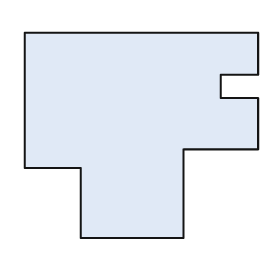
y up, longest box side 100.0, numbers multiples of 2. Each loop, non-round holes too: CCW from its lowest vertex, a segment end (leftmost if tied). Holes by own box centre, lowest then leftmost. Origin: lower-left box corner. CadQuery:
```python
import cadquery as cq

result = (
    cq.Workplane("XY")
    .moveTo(24.0, 0.0)
    .lineTo(68.0, 0.0)
    .lineTo(68.0, 38.0)
    .lineTo(100.0, 38.0)
    .lineTo(100.0, 60.0)
    .lineTo(84.0, 60.0)
    .lineTo(84.0, 70.0)
    .lineTo(100.0, 70.0)
    .lineTo(100.0, 88.0)
    .lineTo(0.0, 88.0)
    .lineTo(0.0, 30.0)
    .lineTo(24.0, 30.0)
    .close()
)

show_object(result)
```